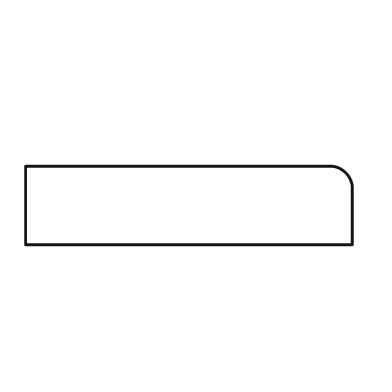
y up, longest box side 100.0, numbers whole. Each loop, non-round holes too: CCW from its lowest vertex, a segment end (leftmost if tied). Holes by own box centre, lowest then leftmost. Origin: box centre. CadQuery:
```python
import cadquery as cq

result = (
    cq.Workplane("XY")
    .moveTo(-50.0, -12.0)
    .lineTo(50.0, -12.0)
    .lineTo(50.0, 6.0)
    .threePointArc((48.0, 10.0), (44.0, 12.0))
    .lineTo(-50.0, 12.0)
    .close()
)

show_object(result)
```